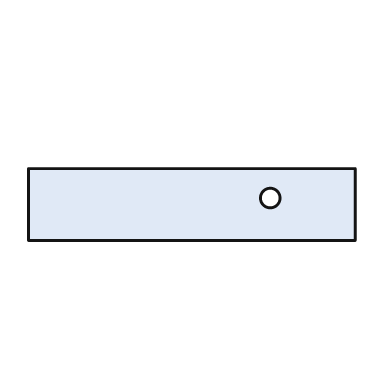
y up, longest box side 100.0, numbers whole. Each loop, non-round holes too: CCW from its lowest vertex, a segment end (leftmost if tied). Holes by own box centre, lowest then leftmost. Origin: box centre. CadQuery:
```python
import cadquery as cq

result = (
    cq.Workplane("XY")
    .moveTo(-50.0, -11.0)
    .lineTo(50.0, -11.0)
    .lineTo(50.0, 11.0)
    .lineTo(-50.0, 11.0)
    .close()
    .moveTo(24.0, 2.0)
    .circle(3.0)
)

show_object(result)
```